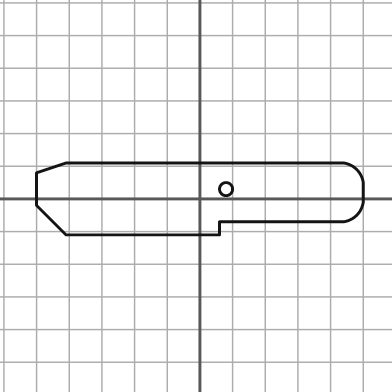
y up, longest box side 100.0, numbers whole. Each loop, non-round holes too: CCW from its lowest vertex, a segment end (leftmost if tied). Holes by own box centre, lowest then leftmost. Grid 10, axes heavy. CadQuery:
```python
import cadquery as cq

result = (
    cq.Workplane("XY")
    .moveTo(-41.0, -11.0)
    .lineTo(6.0, -11.0)
    .lineTo(6.0, -7.0)
    .lineTo(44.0, -7.0)
    .threePointArc((48.0, -5.0), (50.0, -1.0))
    .lineTo(50.0, 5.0)
    .threePointArc((48.0, 9.0), (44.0, 11.0))
    .lineTo(-41.0, 11.0)
    .lineTo(-50.0, 8.0)
    .lineTo(-50.0, -2.0)
    .close()
    .moveTo(8.0, 3.0)
    .circle(2.0)
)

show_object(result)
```